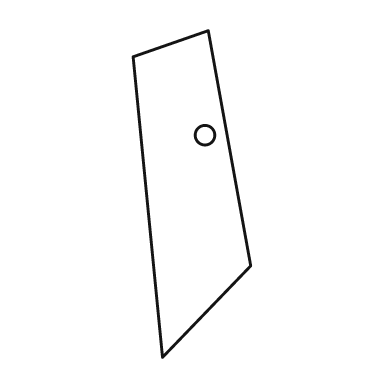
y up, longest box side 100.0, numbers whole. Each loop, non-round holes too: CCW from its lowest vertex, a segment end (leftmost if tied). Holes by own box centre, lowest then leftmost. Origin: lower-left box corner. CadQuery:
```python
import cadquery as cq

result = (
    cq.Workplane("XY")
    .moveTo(9.0, 0.0)
    .lineTo(36.0, 28.0)
    .lineTo(23.0, 100.0)
    .lineTo(0.0, 92.0)
    .close()
    .moveTo(22.0, 68.0)
    .circle(3.0)
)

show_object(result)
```